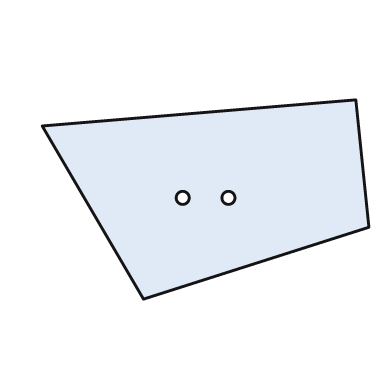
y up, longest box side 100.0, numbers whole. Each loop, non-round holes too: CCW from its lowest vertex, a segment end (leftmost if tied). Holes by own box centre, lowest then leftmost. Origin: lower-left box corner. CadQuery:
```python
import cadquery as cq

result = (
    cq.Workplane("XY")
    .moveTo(31.0, 0.0)
    .lineTo(100.0, 22.0)
    .lineTo(96.0, 61.0)
    .lineTo(0.0, 53.0)
    .close()
    .moveTo(43.0, 31.0)
    .circle(2.0)
    .moveTo(57.0, 31.0)
    .circle(2.0)
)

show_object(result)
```